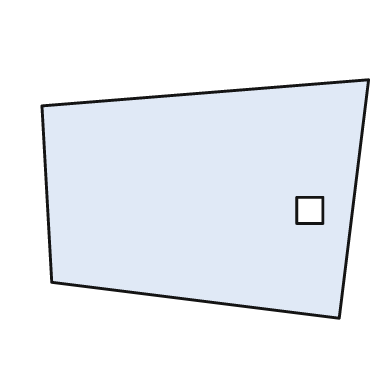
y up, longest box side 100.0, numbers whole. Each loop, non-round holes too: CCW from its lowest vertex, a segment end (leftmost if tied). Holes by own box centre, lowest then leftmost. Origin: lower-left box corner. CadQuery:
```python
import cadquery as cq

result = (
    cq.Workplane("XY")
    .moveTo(91.0, 0.0)
    .lineTo(100.0, 73.0)
    .lineTo(0.0, 65.0)
    .lineTo(3.0, 11.0)
    .close()
    .moveTo(78.0, 29.0)
    .lineTo(86.0, 29.0)
    .lineTo(86.0, 37.0)
    .lineTo(78.0, 37.0)
    .close()
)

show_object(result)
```